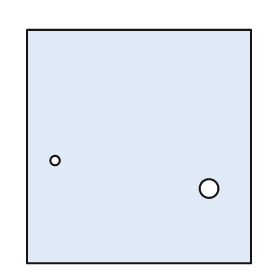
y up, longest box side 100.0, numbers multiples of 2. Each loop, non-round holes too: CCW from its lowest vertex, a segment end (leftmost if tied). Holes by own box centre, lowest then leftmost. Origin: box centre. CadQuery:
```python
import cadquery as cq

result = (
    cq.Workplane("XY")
    .moveTo(-48.0, -50.0)
    .lineTo(48.0, -50.0)
    .lineTo(48.0, 50.0)
    .lineTo(-48.0, 50.0)
    .close()
    .moveTo(30.0, -18.0)
    .circle(4.0)
    .moveTo(-36.0, -6.0)
    .circle(2.0)
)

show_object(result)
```